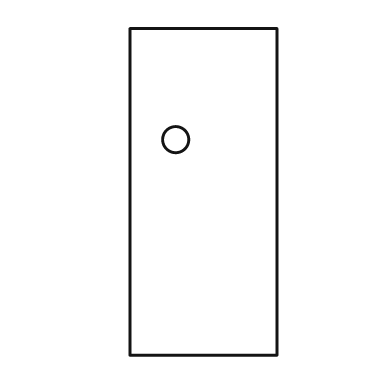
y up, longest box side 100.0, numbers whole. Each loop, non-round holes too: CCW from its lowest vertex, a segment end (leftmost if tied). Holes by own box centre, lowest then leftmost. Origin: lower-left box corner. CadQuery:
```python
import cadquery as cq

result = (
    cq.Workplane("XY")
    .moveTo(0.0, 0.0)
    .lineTo(45.0, 0.0)
    .lineTo(45.0, 100.0)
    .lineTo(0.0, 100.0)
    .close()
    .moveTo(14.0, 66.0)
    .circle(4.0)
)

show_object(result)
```